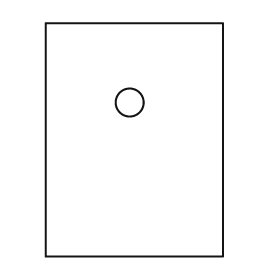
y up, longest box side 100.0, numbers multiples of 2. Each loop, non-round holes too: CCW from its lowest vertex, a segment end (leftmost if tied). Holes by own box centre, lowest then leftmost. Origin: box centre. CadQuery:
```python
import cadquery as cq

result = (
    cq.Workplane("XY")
    .moveTo(-38.0, -50.0)
    .lineTo(38.0, -50.0)
    .lineTo(38.0, 50.0)
    .lineTo(-38.0, 50.0)
    .close()
    .moveTo(-2.0, 16.0)
    .circle(6.0)
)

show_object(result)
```